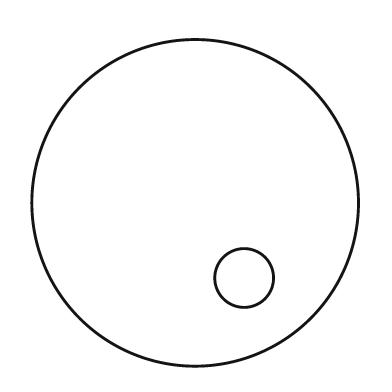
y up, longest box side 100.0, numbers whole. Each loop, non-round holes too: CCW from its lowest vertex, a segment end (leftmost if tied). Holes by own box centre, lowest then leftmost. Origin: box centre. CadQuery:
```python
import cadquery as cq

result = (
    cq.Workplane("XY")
    .moveTo(0.0, 0.0)
    .circle(50.0)
    .moveTo(15.0, -23.0)
    .circle(9.0)
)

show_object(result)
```